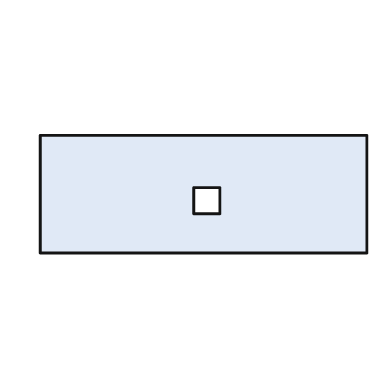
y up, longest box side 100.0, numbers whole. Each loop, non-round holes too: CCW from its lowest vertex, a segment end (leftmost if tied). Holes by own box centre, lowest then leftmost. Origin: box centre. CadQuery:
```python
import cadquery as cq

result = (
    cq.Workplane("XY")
    .moveTo(-50.0, -18.0)
    .lineTo(50.0, -18.0)
    .lineTo(50.0, 18.0)
    .lineTo(-50.0, 18.0)
    .close()
    .moveTo(-3.0, -6.0)
    .lineTo(5.0, -6.0)
    .lineTo(5.0, 2.0)
    .lineTo(-3.0, 2.0)
    .close()
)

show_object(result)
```